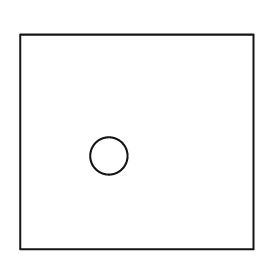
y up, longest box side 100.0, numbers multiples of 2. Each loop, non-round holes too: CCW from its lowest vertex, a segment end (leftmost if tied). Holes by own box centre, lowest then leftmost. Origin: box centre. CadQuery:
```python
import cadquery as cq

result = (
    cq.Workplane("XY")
    .moveTo(-50.0, -46.0)
    .lineTo(50.0, -46.0)
    .lineTo(50.0, 46.0)
    .lineTo(-50.0, 46.0)
    .close()
    .moveTo(-12.0, -6.0)
    .circle(8.0)
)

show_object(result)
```